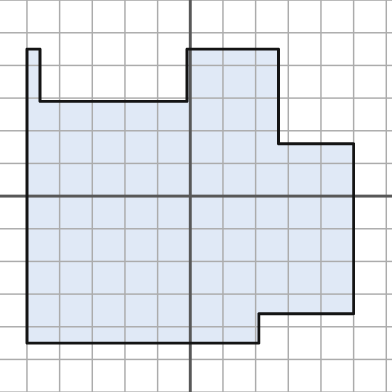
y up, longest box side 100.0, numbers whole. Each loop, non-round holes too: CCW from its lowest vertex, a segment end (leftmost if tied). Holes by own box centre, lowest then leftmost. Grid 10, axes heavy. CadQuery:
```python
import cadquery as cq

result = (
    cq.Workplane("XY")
    .moveTo(-50.0, -45.0)
    .lineTo(21.0, -45.0)
    .lineTo(21.0, -36.0)
    .lineTo(50.0, -36.0)
    .lineTo(50.0, 16.0)
    .lineTo(27.0, 16.0)
    .lineTo(27.0, 45.0)
    .lineTo(-1.0, 45.0)
    .lineTo(-1.0, 29.0)
    .lineTo(-46.0, 29.0)
    .lineTo(-46.0, 45.0)
    .lineTo(-50.0, 45.0)
    .close()
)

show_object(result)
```